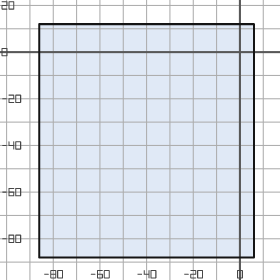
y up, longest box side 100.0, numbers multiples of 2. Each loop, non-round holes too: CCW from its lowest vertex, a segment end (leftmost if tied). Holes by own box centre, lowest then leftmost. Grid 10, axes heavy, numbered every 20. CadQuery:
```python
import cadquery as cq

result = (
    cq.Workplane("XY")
    .moveTo(-86.0, -88.0)
    .lineTo(6.0, -88.0)
    .lineTo(6.0, 12.0)
    .lineTo(-86.0, 12.0)
    .close()
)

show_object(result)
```